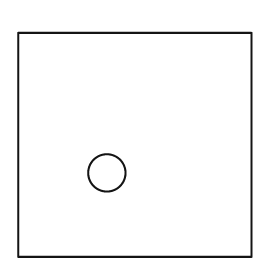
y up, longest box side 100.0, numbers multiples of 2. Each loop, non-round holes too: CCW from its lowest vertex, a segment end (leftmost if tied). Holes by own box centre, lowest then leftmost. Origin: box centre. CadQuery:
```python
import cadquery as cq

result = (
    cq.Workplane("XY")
    .moveTo(-50.0, -48.0)
    .lineTo(50.0, -48.0)
    .lineTo(50.0, 48.0)
    .lineTo(-50.0, 48.0)
    .close()
    .moveTo(-12.0, -12.0)
    .circle(8.0)
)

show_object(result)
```